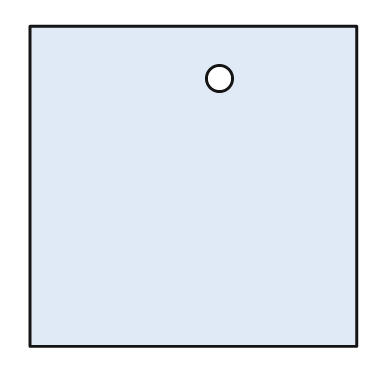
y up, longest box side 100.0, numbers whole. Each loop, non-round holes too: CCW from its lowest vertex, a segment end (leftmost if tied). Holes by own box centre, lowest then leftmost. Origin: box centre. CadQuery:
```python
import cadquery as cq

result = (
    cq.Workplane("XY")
    .moveTo(-50.0, -49.0)
    .lineTo(50.0, -49.0)
    .lineTo(50.0, 49.0)
    .lineTo(-50.0, 49.0)
    .close()
    .moveTo(8.0, 33.0)
    .circle(4.0)
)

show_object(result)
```